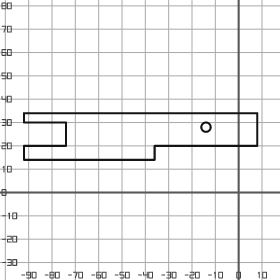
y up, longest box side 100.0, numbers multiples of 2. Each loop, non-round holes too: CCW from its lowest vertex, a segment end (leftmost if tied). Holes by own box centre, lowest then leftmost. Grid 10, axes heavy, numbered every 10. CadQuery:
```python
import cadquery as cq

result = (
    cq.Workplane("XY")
    .moveTo(-92.0, 14.0)
    .lineTo(-36.0, 14.0)
    .lineTo(-36.0, 20.0)
    .lineTo(8.0, 20.0)
    .lineTo(8.0, 34.0)
    .lineTo(-92.0, 34.0)
    .lineTo(-92.0, 30.0)
    .lineTo(-74.0, 30.0)
    .lineTo(-74.0, 20.0)
    .lineTo(-92.0, 20.0)
    .close()
    .moveTo(-14.0, 28.0)
    .circle(2.0)
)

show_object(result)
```